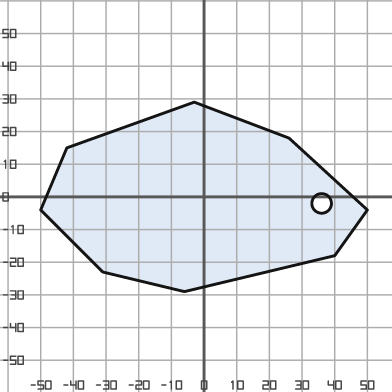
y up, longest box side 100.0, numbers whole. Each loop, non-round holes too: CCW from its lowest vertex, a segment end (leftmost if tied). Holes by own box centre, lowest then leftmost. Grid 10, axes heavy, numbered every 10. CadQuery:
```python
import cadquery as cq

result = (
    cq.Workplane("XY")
    .moveTo(-6.0, -29.0)
    .lineTo(40.0, -18.0)
    .lineTo(50.0, -4.0)
    .lineTo(26.0, 18.0)
    .lineTo(-3.0, 29.0)
    .lineTo(-42.0, 15.0)
    .lineTo(-50.0, -4.0)
    .lineTo(-31.0, -23.0)
    .close()
    .moveTo(36.0, -2.0)
    .circle(3.0)
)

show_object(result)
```